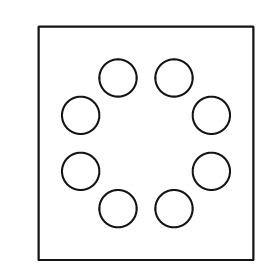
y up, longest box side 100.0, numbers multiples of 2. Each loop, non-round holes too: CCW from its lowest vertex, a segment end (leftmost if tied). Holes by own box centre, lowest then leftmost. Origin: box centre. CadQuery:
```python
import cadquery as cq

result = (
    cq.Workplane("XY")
    .moveTo(-46.0, -50.0)
    .lineTo(46.0, -50.0)
    .lineTo(46.0, 50.0)
    .lineTo(-46.0, 50.0)
    .close()
    .moveTo(-12.0, -28.0)
    .circle(8.0)
    .moveTo(12.0, -28.0)
    .circle(8.0)
    .moveTo(-28.0, -12.0)
    .circle(8.0)
    .moveTo(28.0, -12.0)
    .circle(8.0)
    .moveTo(-28.0, 12.0)
    .circle(8.0)
    .moveTo(28.0, 12.0)
    .circle(8.0)
    .moveTo(-12.0, 28.0)
    .circle(8.0)
    .moveTo(12.0, 28.0)
    .circle(8.0)
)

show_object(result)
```